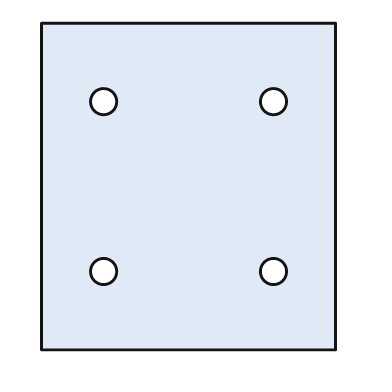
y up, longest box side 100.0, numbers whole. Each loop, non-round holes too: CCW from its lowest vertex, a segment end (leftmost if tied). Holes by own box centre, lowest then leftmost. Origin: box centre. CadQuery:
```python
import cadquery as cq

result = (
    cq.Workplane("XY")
    .moveTo(-45.0, -50.0)
    .lineTo(45.0, -50.0)
    .lineTo(45.0, 50.0)
    .lineTo(-45.0, 50.0)
    .close()
    .moveTo(-26.0, -26.0)
    .circle(4.0)
    .moveTo(26.0, -26.0)
    .circle(4.0)
    .moveTo(-26.0, 26.0)
    .circle(4.0)
    .moveTo(26.0, 26.0)
    .circle(4.0)
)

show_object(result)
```